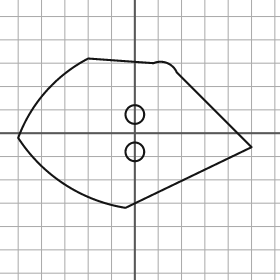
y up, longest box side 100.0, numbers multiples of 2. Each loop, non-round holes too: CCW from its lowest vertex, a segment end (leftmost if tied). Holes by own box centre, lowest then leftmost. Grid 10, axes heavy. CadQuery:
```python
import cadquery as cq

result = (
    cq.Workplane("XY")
    .moveTo(-4.0, -32.0)
    .lineTo(50.0, -6.0)
    .lineTo(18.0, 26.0)
    .threePointArc((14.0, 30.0), (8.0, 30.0))
    .lineTo(-20.0, 32.0)
    .threePointArc((-38.0, 18.0), (-50.0, -2.0))
    .threePointArc((-30.0, -22.0), (-4.0, -32.0))
    .close()
    .moveTo(0.0, -8.0)
    .circle(4.0)
    .moveTo(0.0, 8.0)
    .circle(4.0)
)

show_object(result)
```